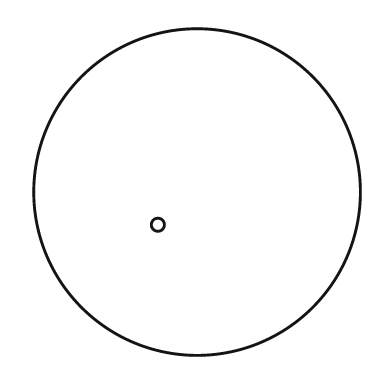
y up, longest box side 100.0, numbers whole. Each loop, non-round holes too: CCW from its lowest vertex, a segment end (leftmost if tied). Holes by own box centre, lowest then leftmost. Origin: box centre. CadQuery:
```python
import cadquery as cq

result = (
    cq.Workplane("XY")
    .moveTo(0.0, 0.0)
    .circle(50.0)
    .moveTo(-12.0, -10.0)
    .circle(2.0)
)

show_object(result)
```